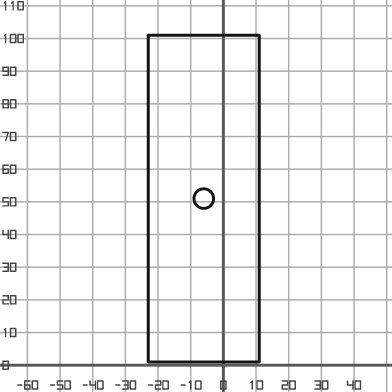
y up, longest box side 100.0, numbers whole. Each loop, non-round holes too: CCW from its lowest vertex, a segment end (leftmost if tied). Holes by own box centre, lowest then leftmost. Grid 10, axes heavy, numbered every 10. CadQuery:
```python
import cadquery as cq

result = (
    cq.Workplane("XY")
    .moveTo(-23.0, 1.0)
    .lineTo(11.0, 1.0)
    .lineTo(11.0, 101.0)
    .lineTo(-23.0, 101.0)
    .close()
    .moveTo(-6.0, 51.0)
    .circle(3.0)
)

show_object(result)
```